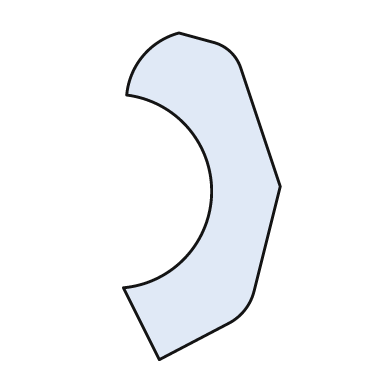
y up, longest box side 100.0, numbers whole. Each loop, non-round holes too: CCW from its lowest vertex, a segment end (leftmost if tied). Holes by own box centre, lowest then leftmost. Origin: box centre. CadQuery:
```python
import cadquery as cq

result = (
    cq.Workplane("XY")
    .moveTo(-13.0, -50.0)
    .lineTo(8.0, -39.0)
    .threePointArc((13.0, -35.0), (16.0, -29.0))
    .lineTo(24.0, 3.0)
    .lineTo(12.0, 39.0)
    .threePointArc((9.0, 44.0), (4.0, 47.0))
    .lineTo(-7.0, 50.0)
    .threePointArc((-18.0, 43.0), (-23.0, 31.0))
    .threePointArc((3.0, 1.0), (-24.0, -28.0))
    .close()
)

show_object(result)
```